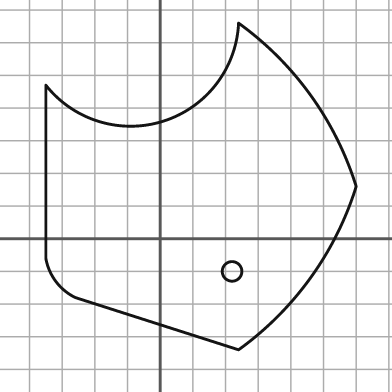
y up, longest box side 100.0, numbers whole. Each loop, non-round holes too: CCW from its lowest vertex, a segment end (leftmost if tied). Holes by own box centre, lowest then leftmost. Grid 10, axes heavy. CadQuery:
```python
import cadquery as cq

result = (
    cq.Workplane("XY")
    .moveTo(24.0, -34.0)
    .threePointArc((46.0, -12.0), (60.0, 16.0))
    .threePointArc((46.0, 44.0), (24.0, 66.0))
    .threePointArc((1.0, 36.0), (-35.0, 47.0))
    .lineTo(-35.0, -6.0)
    .threePointArc((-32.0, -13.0), (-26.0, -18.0))
    .close()
    .moveTo(22.0, -10.0)
    .circle(3.0)
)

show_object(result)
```